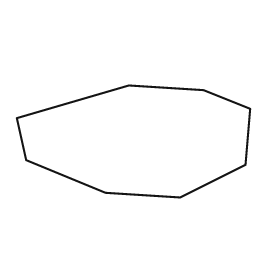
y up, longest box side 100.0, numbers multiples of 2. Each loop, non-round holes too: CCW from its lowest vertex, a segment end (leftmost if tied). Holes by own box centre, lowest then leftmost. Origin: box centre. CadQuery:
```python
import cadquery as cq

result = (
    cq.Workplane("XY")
    .moveTo(20.0, -24.0)
    .lineTo(48.0, -10.0)
    .lineTo(50.0, 14.0)
    .lineTo(30.0, 22.0)
    .lineTo(-2.0, 24.0)
    .lineTo(-50.0, 10.0)
    .lineTo(-46.0, -8.0)
    .lineTo(-12.0, -22.0)
    .close()
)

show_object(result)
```